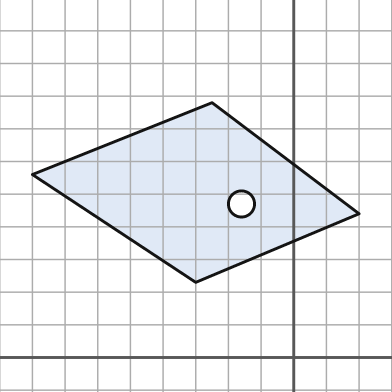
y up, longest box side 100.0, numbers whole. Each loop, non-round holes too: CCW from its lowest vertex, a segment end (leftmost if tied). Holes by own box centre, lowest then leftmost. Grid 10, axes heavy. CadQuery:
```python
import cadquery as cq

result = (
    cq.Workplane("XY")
    .moveTo(-30.0, 23.0)
    .lineTo(20.0, 44.0)
    .lineTo(-25.0, 78.0)
    .lineTo(-80.0, 56.0)
    .close()
    .moveTo(-16.0, 47.0)
    .circle(4.0)
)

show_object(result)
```